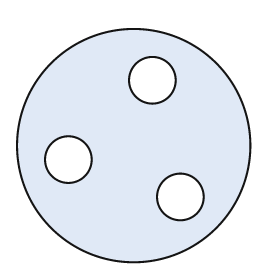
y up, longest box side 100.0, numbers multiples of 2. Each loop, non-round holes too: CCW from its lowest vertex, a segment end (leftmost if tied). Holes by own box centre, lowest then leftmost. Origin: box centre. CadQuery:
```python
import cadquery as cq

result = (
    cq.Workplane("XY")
    .moveTo(0.0, 0.0)
    .circle(50.0)
    .moveTo(20.0, -22.0)
    .circle(10.0)
    .moveTo(-28.0, -6.0)
    .circle(10.0)
    .moveTo(8.0, 28.0)
    .circle(10.0)
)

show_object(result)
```